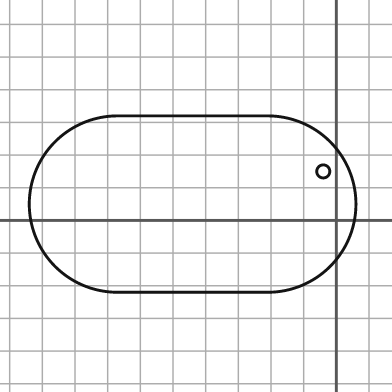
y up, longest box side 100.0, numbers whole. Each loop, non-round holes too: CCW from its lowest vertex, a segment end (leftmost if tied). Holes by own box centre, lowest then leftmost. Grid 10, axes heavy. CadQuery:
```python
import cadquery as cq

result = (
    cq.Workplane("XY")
    .moveTo(-67.0, -22.0)
    .lineTo(-21.0, -22.0)
    .threePointArc((6.0, 5.0), (-21.0, 32.0))
    .lineTo(-67.0, 32.0)
    .threePointArc((-94.0, 5.0), (-67.0, -22.0))
    .close()
    .moveTo(-4.0, 15.0)
    .circle(2.0)
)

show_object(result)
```